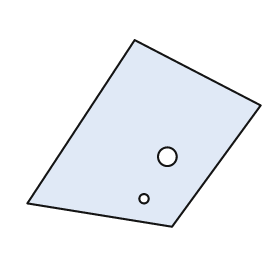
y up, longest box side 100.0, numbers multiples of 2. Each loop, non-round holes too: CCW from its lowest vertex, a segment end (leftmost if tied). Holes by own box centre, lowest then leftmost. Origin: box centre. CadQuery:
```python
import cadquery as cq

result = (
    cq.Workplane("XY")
    .moveTo(12.0, -40.0)
    .lineTo(50.0, 12.0)
    .lineTo(-4.0, 40.0)
    .lineTo(-50.0, -30.0)
    .close()
    .moveTo(0.0, -28.0)
    .circle(2.0)
    .moveTo(10.0, -10.0)
    .circle(4.0)
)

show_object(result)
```